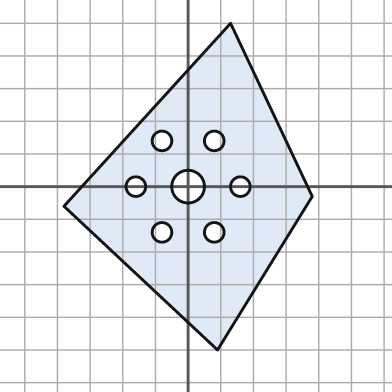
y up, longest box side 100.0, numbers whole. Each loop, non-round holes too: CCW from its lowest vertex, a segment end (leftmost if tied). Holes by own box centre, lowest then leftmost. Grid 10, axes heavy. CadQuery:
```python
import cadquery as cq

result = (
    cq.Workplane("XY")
    .moveTo(9.0, -50.0)
    .lineTo(38.0, -3.0)
    .lineTo(13.0, 50.0)
    .lineTo(-38.0, -6.0)
    .close()
    .moveTo(-8.0, -14.0)
    .circle(3.0)
    .moveTo(8.0, -14.0)
    .circle(3.0)
    .moveTo(-16.0, 0.0)
    .circle(3.0)
    .moveTo(0.0, 0.0)
    .circle(5.0)
    .moveTo(16.0, 0.0)
    .circle(3.0)
    .moveTo(-8.0, 14.0)
    .circle(3.0)
    .moveTo(8.0, 14.0)
    .circle(3.0)
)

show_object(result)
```